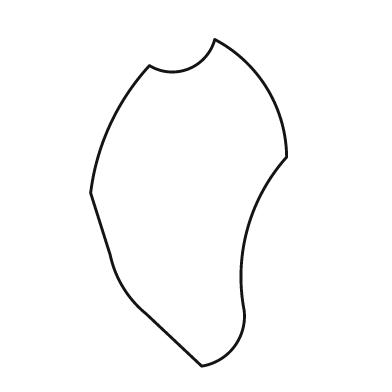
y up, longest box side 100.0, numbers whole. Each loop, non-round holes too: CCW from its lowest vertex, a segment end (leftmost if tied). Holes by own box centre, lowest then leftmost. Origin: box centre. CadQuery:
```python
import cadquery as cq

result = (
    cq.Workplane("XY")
    .moveTo(4.0, -50.0)
    .threePointArc((14.0, -44.0), (17.0, -33.0))
    .threePointArc((18.0, -8.0), (30.0, 14.0))
    .threePointArc((24.0, 35.0), (8.0, 50.0))
    .threePointArc((0.0, 41.0), (-12.0, 42.0))
    .threePointArc((-24.0, 24.0), (-30.0, 3.0))
    .lineTo(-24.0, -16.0)
    .threePointArc((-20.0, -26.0), (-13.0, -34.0))
    .close()
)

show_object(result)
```